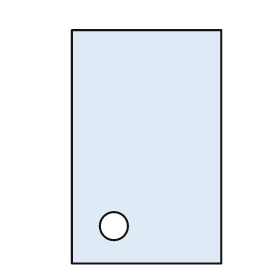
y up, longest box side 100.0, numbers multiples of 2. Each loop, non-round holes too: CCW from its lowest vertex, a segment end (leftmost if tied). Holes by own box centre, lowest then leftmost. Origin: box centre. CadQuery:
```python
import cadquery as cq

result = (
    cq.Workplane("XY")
    .moveTo(-32.0, -50.0)
    .lineTo(32.0, -50.0)
    .lineTo(32.0, 50.0)
    .lineTo(-32.0, 50.0)
    .close()
    .moveTo(-14.0, -34.0)
    .circle(6.0)
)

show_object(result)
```